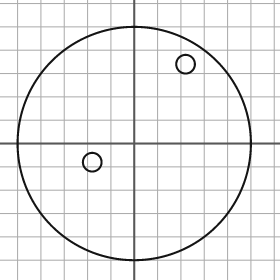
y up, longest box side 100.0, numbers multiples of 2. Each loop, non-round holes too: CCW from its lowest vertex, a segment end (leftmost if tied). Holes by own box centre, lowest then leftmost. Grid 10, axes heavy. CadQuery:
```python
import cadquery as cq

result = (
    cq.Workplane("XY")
    .moveTo(0.0, 0.0)
    .circle(50.0)
    .moveTo(-18.0, -8.0)
    .circle(4.0)
    .moveTo(22.0, 34.0)
    .circle(4.0)
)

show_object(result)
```